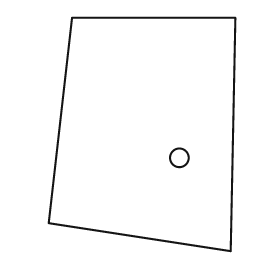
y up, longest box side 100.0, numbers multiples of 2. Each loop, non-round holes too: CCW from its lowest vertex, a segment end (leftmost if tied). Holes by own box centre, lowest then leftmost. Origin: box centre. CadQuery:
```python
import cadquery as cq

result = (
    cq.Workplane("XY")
    .moveTo(38.0, -50.0)
    .lineTo(40.0, 50.0)
    .lineTo(-30.0, 50.0)
    .lineTo(-40.0, -38.0)
    .close()
    .moveTo(16.0, -10.0)
    .circle(4.0)
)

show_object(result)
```